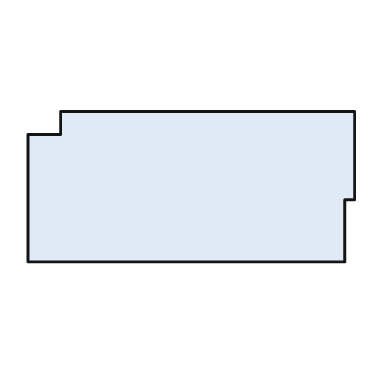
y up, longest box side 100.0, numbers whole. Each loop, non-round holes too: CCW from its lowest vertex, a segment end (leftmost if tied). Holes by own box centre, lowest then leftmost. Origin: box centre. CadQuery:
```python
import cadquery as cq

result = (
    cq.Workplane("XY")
    .moveTo(-50.0, -23.0)
    .lineTo(47.0, -23.0)
    .lineTo(47.0, -4.0)
    .lineTo(50.0, -4.0)
    .lineTo(50.0, 23.0)
    .lineTo(-40.0, 23.0)
    .lineTo(-40.0, 16.0)
    .lineTo(-50.0, 16.0)
    .close()
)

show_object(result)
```